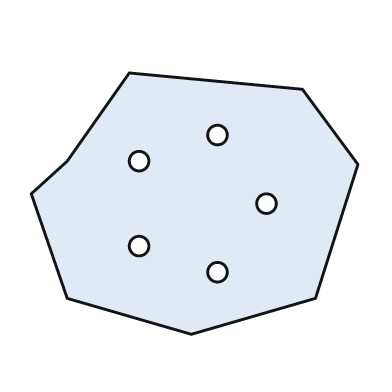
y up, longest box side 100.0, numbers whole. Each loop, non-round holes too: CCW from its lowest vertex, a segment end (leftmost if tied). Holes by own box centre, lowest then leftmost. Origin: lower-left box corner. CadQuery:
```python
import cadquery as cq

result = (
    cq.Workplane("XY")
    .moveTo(49.0, 0.0)
    .lineTo(87.0, 11.0)
    .lineTo(100.0, 52.0)
    .lineTo(83.0, 75.0)
    .lineTo(30.0, 80.0)
    .lineTo(11.0, 53.0)
    .lineTo(0.0, 43.0)
    .lineTo(11.0, 11.0)
    .close()
    .moveTo(57.0, 19.0)
    .circle(3.0)
    .moveTo(33.0, 27.0)
    .circle(3.0)
    .moveTo(72.0, 40.0)
    .circle(3.0)
    .moveTo(33.0, 53.0)
    .circle(3.0)
    .moveTo(57.0, 61.0)
    .circle(3.0)
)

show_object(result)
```